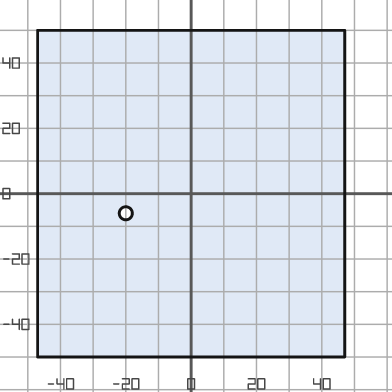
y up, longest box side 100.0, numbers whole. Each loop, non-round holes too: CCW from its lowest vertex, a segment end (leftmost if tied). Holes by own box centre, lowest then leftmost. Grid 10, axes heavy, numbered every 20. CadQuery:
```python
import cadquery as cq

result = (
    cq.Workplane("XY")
    .moveTo(-47.0, -50.0)
    .lineTo(47.0, -50.0)
    .lineTo(47.0, 50.0)
    .lineTo(-47.0, 50.0)
    .close()
    .moveTo(-20.0, -6.0)
    .circle(2.0)
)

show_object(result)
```